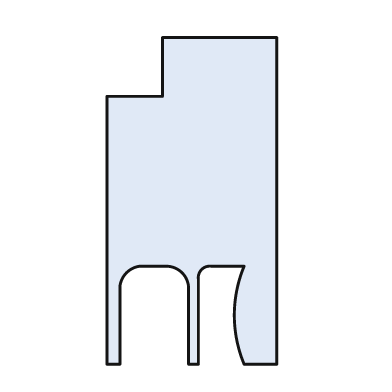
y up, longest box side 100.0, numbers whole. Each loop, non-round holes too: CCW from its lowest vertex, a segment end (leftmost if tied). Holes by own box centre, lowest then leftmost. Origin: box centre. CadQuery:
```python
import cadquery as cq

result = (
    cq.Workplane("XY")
    .moveTo(-26.0, -50.0)
    .lineTo(-22.0, -50.0)
    .lineTo(-22.0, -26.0)
    .threePointArc((-20.0, -22.0), (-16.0, -20.0))
    .lineTo(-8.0, -20.0)
    .threePointArc((-3.0, -22.0), (-1.0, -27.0))
    .lineTo(-1.0, -50.0)
    .lineTo(2.0, -50.0)
    .lineTo(2.0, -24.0)
    .threePointArc((3.0, -21.0), (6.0, -20.0))
    .lineTo(16.0, -20.0)
    .threePointArc((13.0, -35.0), (16.0, -50.0))
    .lineTo(26.0, -50.0)
    .lineTo(26.0, 50.0)
    .lineTo(-9.0, 50.0)
    .lineTo(-9.0, 32.0)
    .lineTo(-26.0, 32.0)
    .close()
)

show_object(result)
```